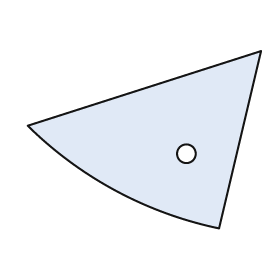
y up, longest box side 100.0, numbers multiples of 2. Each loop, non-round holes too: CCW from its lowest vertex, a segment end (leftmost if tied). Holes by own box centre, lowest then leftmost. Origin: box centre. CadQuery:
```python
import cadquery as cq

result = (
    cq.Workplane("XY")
    .moveTo(32.0, -38.0)
    .lineTo(50.0, 38.0)
    .lineTo(-50.0, 6.0)
    .threePointArc((-12.0, -22.0), (32.0, -38.0))
    .close()
    .moveTo(18.0, -6.0)
    .circle(4.0)
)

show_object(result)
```